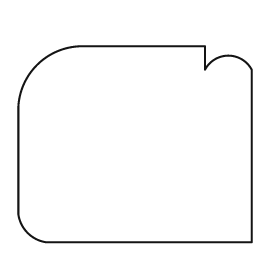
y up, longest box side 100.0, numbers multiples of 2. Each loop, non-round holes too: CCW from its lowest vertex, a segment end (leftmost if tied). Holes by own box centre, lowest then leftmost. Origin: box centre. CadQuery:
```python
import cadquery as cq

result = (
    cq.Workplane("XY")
    .moveTo(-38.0, -42.0)
    .lineTo(50.0, -42.0)
    .lineTo(50.0, 32.0)
    .threePointArc((40.0, 38.0), (30.0, 32.0))
    .lineTo(30.0, 42.0)
    .lineTo(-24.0, 42.0)
    .threePointArc((-42.0, 34.0), (-50.0, 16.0))
    .lineTo(-50.0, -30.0)
    .threePointArc((-46.0, -38.0), (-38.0, -42.0))
    .close()
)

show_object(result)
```